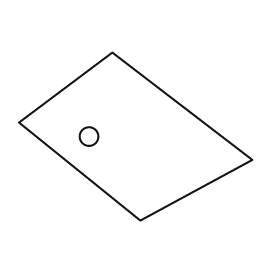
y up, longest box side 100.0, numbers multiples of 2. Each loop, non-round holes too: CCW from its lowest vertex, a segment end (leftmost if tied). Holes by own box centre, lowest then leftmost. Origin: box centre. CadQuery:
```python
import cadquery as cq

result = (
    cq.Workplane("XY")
    .moveTo(2.0, -36.0)
    .lineTo(50.0, -10.0)
    .lineTo(-10.0, 36.0)
    .lineTo(-50.0, 6.0)
    .close()
    .moveTo(-20.0, 0.0)
    .circle(4.0)
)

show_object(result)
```